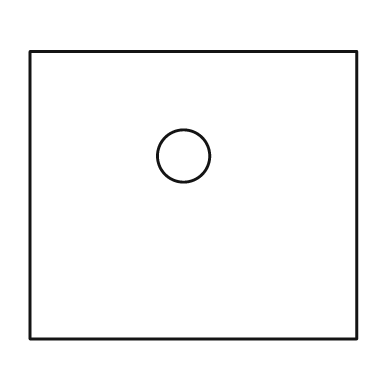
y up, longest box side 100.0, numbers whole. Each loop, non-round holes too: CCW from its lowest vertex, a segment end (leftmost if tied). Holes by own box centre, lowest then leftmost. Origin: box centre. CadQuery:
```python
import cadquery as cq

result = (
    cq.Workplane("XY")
    .moveTo(-50.0, -44.0)
    .lineTo(50.0, -44.0)
    .lineTo(50.0, 44.0)
    .lineTo(-50.0, 44.0)
    .close()
    .moveTo(-3.0, 12.0)
    .circle(8.0)
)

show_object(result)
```